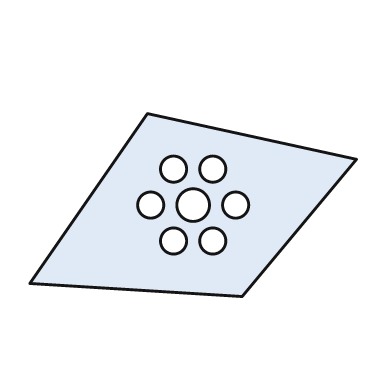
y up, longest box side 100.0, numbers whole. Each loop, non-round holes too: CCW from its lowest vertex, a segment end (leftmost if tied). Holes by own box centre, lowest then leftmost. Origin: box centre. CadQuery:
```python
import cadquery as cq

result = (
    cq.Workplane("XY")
    .moveTo(15.0, -28.0)
    .lineTo(50.0, 14.0)
    .lineTo(-14.0, 28.0)
    .lineTo(-50.0, -24.0)
    .close()
    .moveTo(-6.0, -11.0)
    .circle(4.0)
    .moveTo(6.0, -11.0)
    .circle(4.0)
    .moveTo(-13.0, 0.0)
    .circle(4.0)
    .moveTo(0.0, 0.0)
    .circle(5.0)
    .moveTo(13.0, 0.0)
    .circle(4.0)
    .moveTo(-6.0, 11.0)
    .circle(4.0)
    .moveTo(6.0, 11.0)
    .circle(4.0)
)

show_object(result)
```